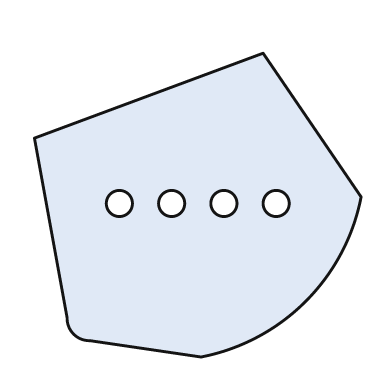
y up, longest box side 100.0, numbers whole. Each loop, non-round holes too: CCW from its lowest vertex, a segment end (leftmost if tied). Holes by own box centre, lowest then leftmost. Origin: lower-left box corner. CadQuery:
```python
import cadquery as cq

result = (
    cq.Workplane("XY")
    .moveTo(51.0, 0.0)
    .threePointArc((83.0, 17.0), (100.0, 49.0))
    .lineTo(70.0, 93.0)
    .lineTo(0.0, 67.0)
    .lineTo(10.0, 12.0)
    .threePointArc((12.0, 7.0), (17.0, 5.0))
    .close()
    .moveTo(26.0, 47.0)
    .circle(4.0)
    .moveTo(42.0, 47.0)
    .circle(4.0)
    .moveTo(58.0, 47.0)
    .circle(4.0)
    .moveTo(74.0, 47.0)
    .circle(4.0)
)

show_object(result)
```